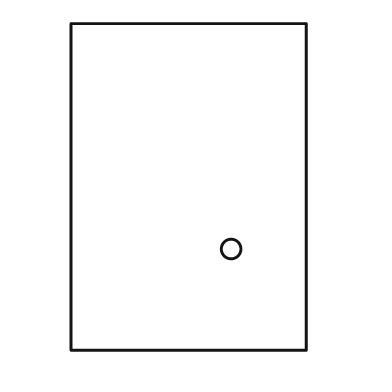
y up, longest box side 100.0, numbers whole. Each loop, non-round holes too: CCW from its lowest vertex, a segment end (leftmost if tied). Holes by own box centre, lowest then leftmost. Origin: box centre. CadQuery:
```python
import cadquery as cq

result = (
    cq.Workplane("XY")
    .moveTo(-36.0, -50.0)
    .lineTo(36.0, -50.0)
    .lineTo(36.0, 50.0)
    .lineTo(-36.0, 50.0)
    .close()
    .moveTo(13.0, -19.0)
    .circle(3.0)
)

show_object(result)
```